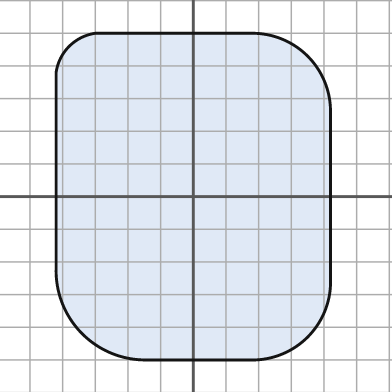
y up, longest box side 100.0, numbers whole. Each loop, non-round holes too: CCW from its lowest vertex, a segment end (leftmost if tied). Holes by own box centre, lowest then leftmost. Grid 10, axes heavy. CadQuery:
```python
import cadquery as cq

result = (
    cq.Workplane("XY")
    .moveTo(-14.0, -50.0)
    .lineTo(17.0, -50.0)
    .threePointArc((35.0, -43.0), (42.0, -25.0))
    .lineTo(42.0, 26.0)
    .threePointArc((35.0, 43.0), (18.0, 50.0))
    .lineTo(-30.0, 50.0)
    .threePointArc((-38.0, 46.0), (-42.0, 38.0))
    .lineTo(-42.0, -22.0)
    .threePointArc((-34.0, -42.0), (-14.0, -50.0))
    .close()
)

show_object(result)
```